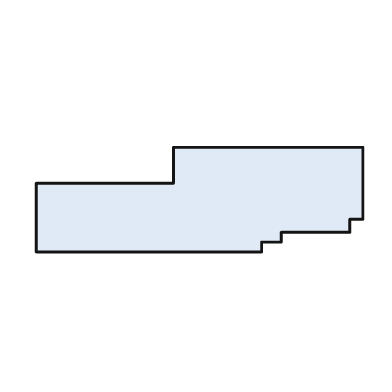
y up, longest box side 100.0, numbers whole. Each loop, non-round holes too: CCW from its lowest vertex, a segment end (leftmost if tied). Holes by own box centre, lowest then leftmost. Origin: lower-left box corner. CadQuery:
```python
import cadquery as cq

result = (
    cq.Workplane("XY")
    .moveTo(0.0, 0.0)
    .lineTo(69.0, 0.0)
    .lineTo(69.0, 3.0)
    .lineTo(75.0, 3.0)
    .lineTo(75.0, 6.0)
    .lineTo(96.0, 6.0)
    .lineTo(96.0, 10.0)
    .lineTo(100.0, 10.0)
    .lineTo(100.0, 32.0)
    .lineTo(42.0, 32.0)
    .lineTo(42.0, 21.0)
    .lineTo(0.0, 21.0)
    .close()
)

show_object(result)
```